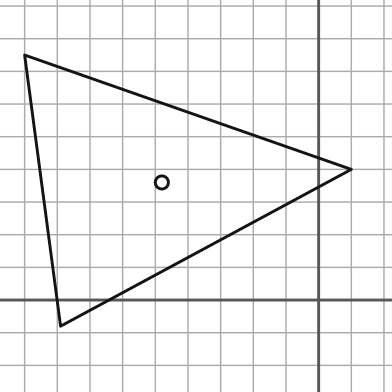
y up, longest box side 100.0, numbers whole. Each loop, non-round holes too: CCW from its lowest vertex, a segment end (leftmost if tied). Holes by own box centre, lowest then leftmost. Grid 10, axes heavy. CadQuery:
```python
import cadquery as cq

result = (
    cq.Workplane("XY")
    .moveTo(-79.0, -8.0)
    .lineTo(10.0, 40.0)
    .lineTo(-90.0, 75.0)
    .close()
    .moveTo(-48.0, 36.0)
    .circle(2.0)
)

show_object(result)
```